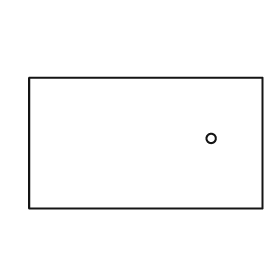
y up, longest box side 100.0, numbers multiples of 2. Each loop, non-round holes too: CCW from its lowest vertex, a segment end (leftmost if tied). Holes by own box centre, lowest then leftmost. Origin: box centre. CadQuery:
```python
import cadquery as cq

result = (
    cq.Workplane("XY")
    .moveTo(-50.0, -28.0)
    .lineTo(50.0, -28.0)
    .lineTo(50.0, 28.0)
    .lineTo(-50.0, 28.0)
    .close()
    .moveTo(28.0, 2.0)
    .circle(2.0)
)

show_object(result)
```